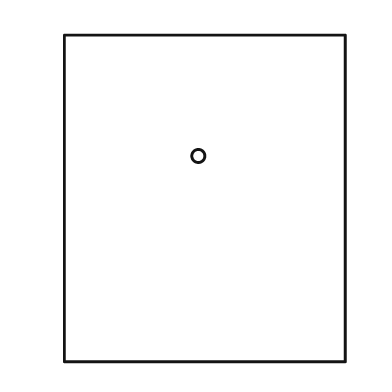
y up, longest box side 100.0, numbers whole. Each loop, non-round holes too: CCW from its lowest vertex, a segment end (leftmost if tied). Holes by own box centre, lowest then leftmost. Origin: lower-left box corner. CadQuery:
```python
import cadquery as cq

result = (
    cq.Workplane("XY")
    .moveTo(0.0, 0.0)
    .lineTo(86.0, 0.0)
    .lineTo(86.0, 100.0)
    .lineTo(0.0, 100.0)
    .close()
    .moveTo(41.0, 63.0)
    .circle(2.0)
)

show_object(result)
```